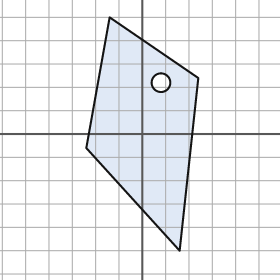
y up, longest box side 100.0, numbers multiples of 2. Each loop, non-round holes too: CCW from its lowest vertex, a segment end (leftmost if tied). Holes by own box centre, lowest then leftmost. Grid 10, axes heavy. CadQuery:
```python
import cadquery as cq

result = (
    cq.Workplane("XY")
    .moveTo(16.0, -50.0)
    .lineTo(24.0, 24.0)
    .lineTo(-14.0, 50.0)
    .lineTo(-24.0, -6.0)
    .close()
    .moveTo(8.0, 22.0)
    .circle(4.0)
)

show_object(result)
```